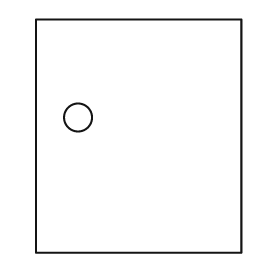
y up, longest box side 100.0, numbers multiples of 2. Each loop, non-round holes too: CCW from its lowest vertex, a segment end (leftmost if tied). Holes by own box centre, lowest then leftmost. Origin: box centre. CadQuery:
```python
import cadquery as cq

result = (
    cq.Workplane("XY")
    .moveTo(-44.0, -50.0)
    .lineTo(44.0, -50.0)
    .lineTo(44.0, 50.0)
    .lineTo(-44.0, 50.0)
    .close()
    .moveTo(-26.0, 8.0)
    .circle(6.0)
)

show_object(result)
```